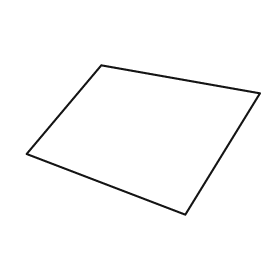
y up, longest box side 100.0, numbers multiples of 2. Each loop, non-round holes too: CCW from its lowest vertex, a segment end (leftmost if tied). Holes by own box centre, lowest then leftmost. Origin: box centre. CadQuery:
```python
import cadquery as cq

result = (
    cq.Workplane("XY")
    .moveTo(18.0, -32.0)
    .lineTo(50.0, 20.0)
    .lineTo(-18.0, 32.0)
    .lineTo(-50.0, -6.0)
    .close()
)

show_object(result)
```